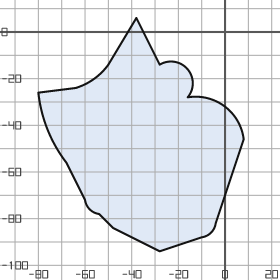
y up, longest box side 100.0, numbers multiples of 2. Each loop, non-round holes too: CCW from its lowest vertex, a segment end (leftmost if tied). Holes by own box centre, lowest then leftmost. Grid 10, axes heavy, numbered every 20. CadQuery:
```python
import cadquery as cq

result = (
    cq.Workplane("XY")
    .moveTo(-28.0, -94.0)
    .lineTo(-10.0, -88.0)
    .threePointArc((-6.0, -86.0), (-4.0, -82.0))
    .lineTo(8.0, -46.0)
    .threePointArc((0.0, -32.0), (-16.0, -28.0))
    .threePointArc((-16.0, -16.0), (-28.0, -14.0))
    .lineTo(-38.0, 6.0)
    .lineTo(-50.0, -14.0)
    .threePointArc((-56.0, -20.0), (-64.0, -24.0))
    .lineTo(-80.0, -26.0)
    .threePointArc((-76.0, -42.0), (-68.0, -56.0))
    .lineTo(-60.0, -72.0)
    .threePointArc((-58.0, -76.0), (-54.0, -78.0))
    .lineTo(-48.0, -84.0)
    .close()
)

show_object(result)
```